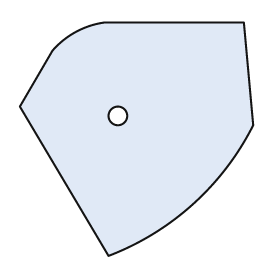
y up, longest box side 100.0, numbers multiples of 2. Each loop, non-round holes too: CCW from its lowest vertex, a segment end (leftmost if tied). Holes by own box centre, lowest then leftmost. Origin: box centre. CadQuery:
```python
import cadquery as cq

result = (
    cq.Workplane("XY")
    .moveTo(-12.0, -50.0)
    .threePointArc((24.0, -28.0), (50.0, 6.0))
    .lineTo(46.0, 50.0)
    .lineTo(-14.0, 50.0)
    .threePointArc((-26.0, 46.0), (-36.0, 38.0))
    .lineTo(-50.0, 14.0)
    .close()
    .moveTo(-8.0, 10.0)
    .circle(4.0)
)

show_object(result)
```